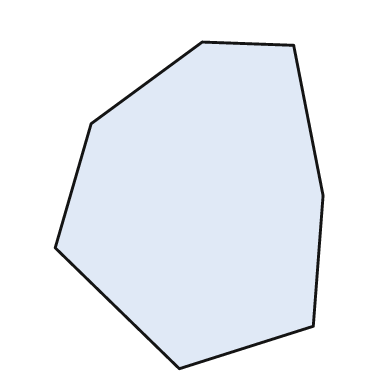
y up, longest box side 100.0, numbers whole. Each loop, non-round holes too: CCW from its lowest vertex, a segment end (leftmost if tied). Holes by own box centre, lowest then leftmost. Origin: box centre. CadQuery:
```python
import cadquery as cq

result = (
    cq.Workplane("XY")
    .moveTo(-3.0, -50.0)
    .lineTo(38.0, -37.0)
    .lineTo(41.0, 3.0)
    .lineTo(32.0, 49.0)
    .lineTo(4.0, 50.0)
    .lineTo(-30.0, 25.0)
    .lineTo(-41.0, -13.0)
    .close()
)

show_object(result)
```